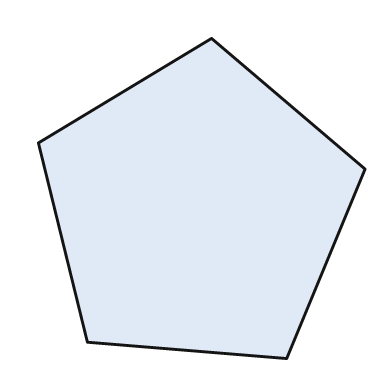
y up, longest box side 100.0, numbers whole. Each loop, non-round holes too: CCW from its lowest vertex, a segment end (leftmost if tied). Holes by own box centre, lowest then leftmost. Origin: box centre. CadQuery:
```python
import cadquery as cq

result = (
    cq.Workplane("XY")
    .moveTo(26.0, -49.0)
    .lineTo(50.0, 9.0)
    .lineTo(3.0, 49.0)
    .lineTo(-50.0, 17.0)
    .lineTo(-35.0, -44.0)
    .close()
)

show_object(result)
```